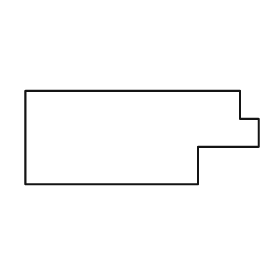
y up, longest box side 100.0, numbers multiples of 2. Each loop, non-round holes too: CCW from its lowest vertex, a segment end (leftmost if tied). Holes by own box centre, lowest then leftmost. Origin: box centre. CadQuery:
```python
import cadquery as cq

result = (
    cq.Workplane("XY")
    .moveTo(-50.0, -20.0)
    .lineTo(24.0, -20.0)
    .lineTo(24.0, -4.0)
    .lineTo(50.0, -4.0)
    .lineTo(50.0, 8.0)
    .lineTo(42.0, 8.0)
    .lineTo(42.0, 20.0)
    .lineTo(-50.0, 20.0)
    .close()
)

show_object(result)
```